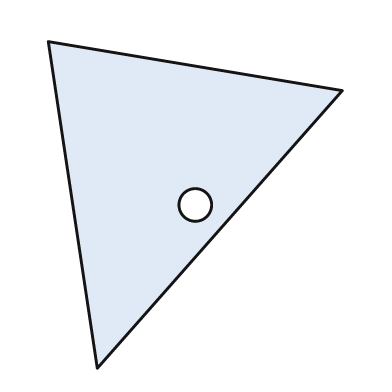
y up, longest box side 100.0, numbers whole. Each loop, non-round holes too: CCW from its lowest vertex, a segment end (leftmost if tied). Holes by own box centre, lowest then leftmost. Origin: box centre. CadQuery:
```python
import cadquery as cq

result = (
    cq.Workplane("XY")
    .moveTo(-30.0, -50.0)
    .lineTo(45.0, 35.0)
    .lineTo(-45.0, 50.0)
    .close()
    .moveTo(0.0, 0.0)
    .circle(5.0)
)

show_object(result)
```